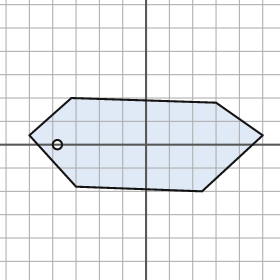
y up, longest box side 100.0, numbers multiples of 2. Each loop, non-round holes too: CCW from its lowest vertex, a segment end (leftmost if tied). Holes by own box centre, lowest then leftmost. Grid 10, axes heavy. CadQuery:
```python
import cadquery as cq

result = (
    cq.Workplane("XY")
    .moveTo(24.0, -20.0)
    .lineTo(50.0, 4.0)
    .lineTo(30.0, 18.0)
    .lineTo(-32.0, 20.0)
    .lineTo(-50.0, 4.0)
    .lineTo(-30.0, -18.0)
    .close()
    .moveTo(-38.0, 0.0)
    .circle(2.0)
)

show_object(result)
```